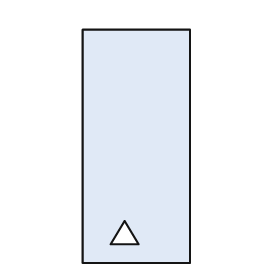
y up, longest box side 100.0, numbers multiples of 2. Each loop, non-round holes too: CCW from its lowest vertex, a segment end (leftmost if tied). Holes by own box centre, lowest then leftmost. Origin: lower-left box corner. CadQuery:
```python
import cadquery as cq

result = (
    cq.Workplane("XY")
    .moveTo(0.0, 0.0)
    .lineTo(46.0, 0.0)
    .lineTo(46.0, 100.0)
    .lineTo(0.0, 100.0)
    .close()
    .moveTo(12.0, 8.0)
    .lineTo(24.0, 8.0)
    .lineTo(18.0, 18.0)
    .close()
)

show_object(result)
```